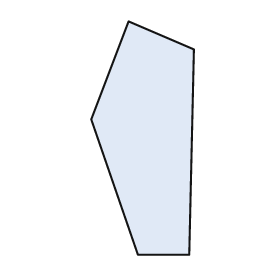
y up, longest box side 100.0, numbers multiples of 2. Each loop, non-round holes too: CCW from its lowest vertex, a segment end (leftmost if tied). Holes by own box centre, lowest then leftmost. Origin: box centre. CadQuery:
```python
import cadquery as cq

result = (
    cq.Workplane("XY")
    .moveTo(-2.0, -50.0)
    .lineTo(20.0, -50.0)
    .lineTo(22.0, 38.0)
    .lineTo(-6.0, 50.0)
    .lineTo(-22.0, 8.0)
    .close()
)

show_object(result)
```